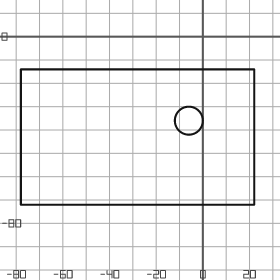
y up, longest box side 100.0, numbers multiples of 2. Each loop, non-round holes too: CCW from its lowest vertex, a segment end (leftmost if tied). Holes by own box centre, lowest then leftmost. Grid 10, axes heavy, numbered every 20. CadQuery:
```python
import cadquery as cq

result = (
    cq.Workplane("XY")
    .moveTo(-78.0, -72.0)
    .lineTo(22.0, -72.0)
    .lineTo(22.0, -14.0)
    .lineTo(-78.0, -14.0)
    .close()
    .moveTo(-6.0, -36.0)
    .circle(6.0)
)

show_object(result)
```